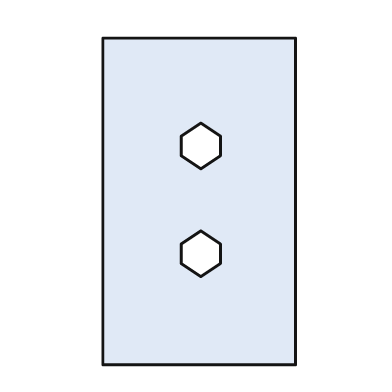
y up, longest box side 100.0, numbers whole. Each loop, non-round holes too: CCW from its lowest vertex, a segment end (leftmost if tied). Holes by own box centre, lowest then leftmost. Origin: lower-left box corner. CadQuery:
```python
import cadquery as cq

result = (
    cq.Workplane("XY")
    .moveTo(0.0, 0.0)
    .lineTo(59.0, 0.0)
    .lineTo(59.0, 100.0)
    .lineTo(0.0, 100.0)
    .close()
    .moveTo(30.0, 27.0)
    .lineTo(36.0, 31.0)
    .lineTo(36.0, 37.0)
    .lineTo(30.0, 41.0)
    .lineTo(24.0, 37.0)
    .lineTo(24.0, 31.0)
    .close()
    .moveTo(30.0, 60.0)
    .lineTo(36.0, 64.0)
    .lineTo(36.0, 70.0)
    .lineTo(30.0, 74.0)
    .lineTo(24.0, 70.0)
    .lineTo(24.0, 64.0)
    .close()
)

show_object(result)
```